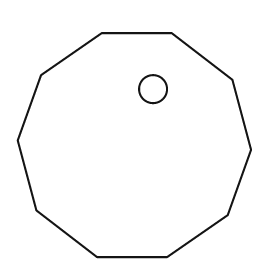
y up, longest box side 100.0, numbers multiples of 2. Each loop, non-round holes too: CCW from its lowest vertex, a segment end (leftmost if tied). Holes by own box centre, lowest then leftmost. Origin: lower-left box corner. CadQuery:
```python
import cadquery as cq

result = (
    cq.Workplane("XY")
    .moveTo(34.0, 0.0)
    .lineTo(64.0, 0.0)
    .lineTo(90.0, 18.0)
    .lineTo(100.0, 46.0)
    .lineTo(92.0, 76.0)
    .lineTo(66.0, 96.0)
    .lineTo(36.0, 96.0)
    .lineTo(10.0, 78.0)
    .lineTo(0.0, 50.0)
    .lineTo(8.0, 20.0)
    .close()
    .moveTo(58.0, 72.0)
    .circle(6.0)
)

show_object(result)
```